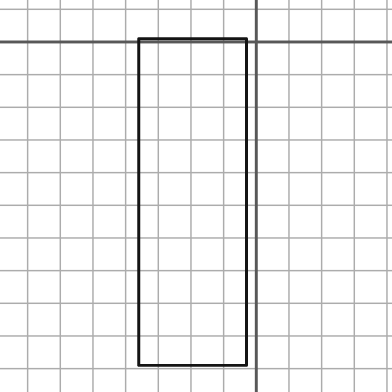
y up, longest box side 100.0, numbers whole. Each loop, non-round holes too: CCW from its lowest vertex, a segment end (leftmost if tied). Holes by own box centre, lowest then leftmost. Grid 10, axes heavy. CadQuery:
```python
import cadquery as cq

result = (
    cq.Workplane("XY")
    .moveTo(-36.0, -99.0)
    .lineTo(-3.0, -99.0)
    .lineTo(-3.0, 1.0)
    .lineTo(-36.0, 1.0)
    .close()
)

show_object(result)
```